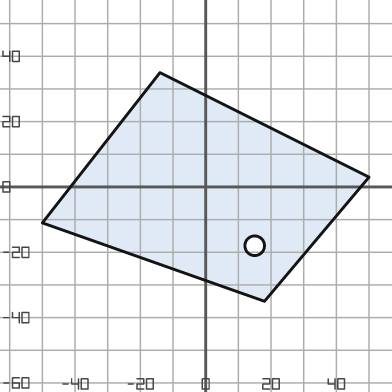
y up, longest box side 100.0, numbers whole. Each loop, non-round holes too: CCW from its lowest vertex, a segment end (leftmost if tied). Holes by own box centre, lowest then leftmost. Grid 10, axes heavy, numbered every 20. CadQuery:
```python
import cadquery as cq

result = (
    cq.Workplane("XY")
    .moveTo(18.0, -35.0)
    .lineTo(50.0, 3.0)
    .lineTo(-14.0, 35.0)
    .lineTo(-50.0, -11.0)
    .close()
    .moveTo(15.0, -18.0)
    .circle(3.0)
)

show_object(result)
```